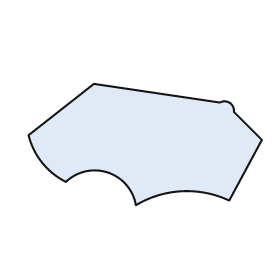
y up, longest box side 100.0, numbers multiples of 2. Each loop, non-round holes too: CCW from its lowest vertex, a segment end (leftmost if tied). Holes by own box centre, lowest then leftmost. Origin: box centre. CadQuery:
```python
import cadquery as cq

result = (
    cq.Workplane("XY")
    .moveTo(-4.0, -26.0)
    .threePointArc((16.0, -20.0), (36.0, -24.0))
    .lineTo(50.0, 2.0)
    .lineTo(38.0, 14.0)
    .threePointArc((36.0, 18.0), (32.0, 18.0))
    .lineTo(-22.0, 26.0)
    .lineTo(-50.0, 4.0)
    .threePointArc((-44.0, -8.0), (-34.0, -16.0))
    .threePointArc((-16.0, -12.0), (-4.0, -26.0))
    .close()
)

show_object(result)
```